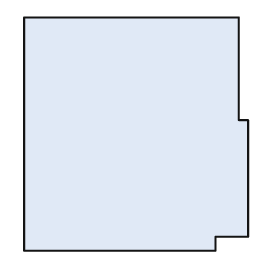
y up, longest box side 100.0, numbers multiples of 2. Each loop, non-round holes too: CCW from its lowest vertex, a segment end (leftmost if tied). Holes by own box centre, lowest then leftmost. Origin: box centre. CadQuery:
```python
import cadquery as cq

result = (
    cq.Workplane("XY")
    .moveTo(-48.0, -50.0)
    .lineTo(34.0, -50.0)
    .lineTo(34.0, -44.0)
    .lineTo(48.0, -44.0)
    .lineTo(48.0, 6.0)
    .lineTo(44.0, 6.0)
    .lineTo(44.0, 50.0)
    .lineTo(-48.0, 50.0)
    .close()
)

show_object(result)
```